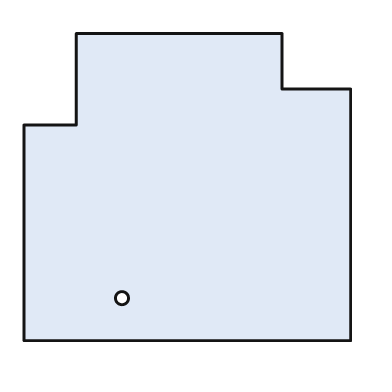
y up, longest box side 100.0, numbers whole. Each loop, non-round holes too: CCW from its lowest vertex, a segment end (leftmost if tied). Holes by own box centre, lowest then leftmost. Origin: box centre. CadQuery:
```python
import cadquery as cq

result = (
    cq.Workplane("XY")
    .moveTo(-50.0, -47.0)
    .lineTo(50.0, -47.0)
    .lineTo(50.0, 30.0)
    .lineTo(29.0, 30.0)
    .lineTo(29.0, 47.0)
    .lineTo(-34.0, 47.0)
    .lineTo(-34.0, 19.0)
    .lineTo(-50.0, 19.0)
    .close()
    .moveTo(-20.0, -34.0)
    .circle(2.0)
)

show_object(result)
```